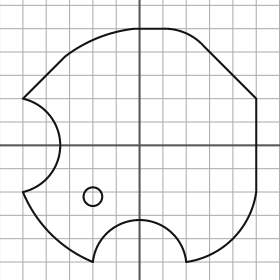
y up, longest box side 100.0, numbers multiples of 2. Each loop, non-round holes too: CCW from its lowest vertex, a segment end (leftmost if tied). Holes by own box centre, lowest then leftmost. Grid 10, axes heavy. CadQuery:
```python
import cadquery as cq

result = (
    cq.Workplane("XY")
    .moveTo(-20.0, -50.0)
    .threePointArc((0.0, -32.0), (20.0, -50.0))
    .threePointArc((40.0, -40.0), (50.0, -20.0))
    .lineTo(50.0, 20.0)
    .lineTo(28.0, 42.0)
    .threePointArc((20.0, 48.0), (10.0, 50.0))
    .lineTo(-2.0, 50.0)
    .threePointArc((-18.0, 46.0), (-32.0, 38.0))
    .lineTo(-50.0, 20.0)
    .threePointArc((-34.0, 0.0), (-50.0, -20.0))
    .threePointArc((-38.0, -38.0), (-20.0, -50.0))
    .close()
    .moveTo(-20.0, -22.0)
    .circle(4.0)
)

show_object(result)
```